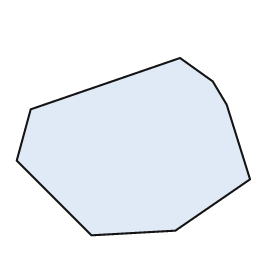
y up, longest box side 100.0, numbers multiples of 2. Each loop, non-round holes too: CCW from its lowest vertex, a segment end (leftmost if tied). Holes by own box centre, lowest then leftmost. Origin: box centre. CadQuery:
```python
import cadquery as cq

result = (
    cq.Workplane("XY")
    .moveTo(-18.0, -38.0)
    .lineTo(18.0, -36.0)
    .lineTo(50.0, -14.0)
    .lineTo(40.0, 18.0)
    .lineTo(34.0, 28.0)
    .lineTo(20.0, 38.0)
    .lineTo(-44.0, 16.0)
    .lineTo(-50.0, -6.0)
    .close()
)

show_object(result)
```